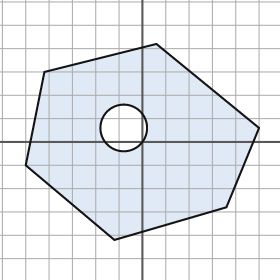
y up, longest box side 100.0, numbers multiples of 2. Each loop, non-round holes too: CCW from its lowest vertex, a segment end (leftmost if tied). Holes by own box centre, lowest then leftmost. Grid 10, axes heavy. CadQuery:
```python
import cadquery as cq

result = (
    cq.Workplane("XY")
    .moveTo(-12.0, -42.0)
    .lineTo(36.0, -28.0)
    .lineTo(50.0, 6.0)
    .lineTo(6.0, 42.0)
    .lineTo(-42.0, 30.0)
    .lineTo(-50.0, -10.0)
    .close()
    .moveTo(-8.0, 6.0)
    .circle(10.0)
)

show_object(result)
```